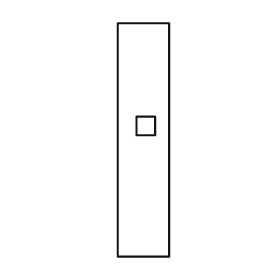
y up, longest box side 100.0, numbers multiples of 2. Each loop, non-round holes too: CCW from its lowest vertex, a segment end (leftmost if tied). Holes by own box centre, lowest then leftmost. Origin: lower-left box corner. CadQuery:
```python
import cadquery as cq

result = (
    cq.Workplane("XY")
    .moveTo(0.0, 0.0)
    .lineTo(22.0, 0.0)
    .lineTo(22.0, 100.0)
    .lineTo(0.0, 100.0)
    .close()
    .moveTo(8.0, 52.0)
    .lineTo(16.0, 52.0)
    .lineTo(16.0, 60.0)
    .lineTo(8.0, 60.0)
    .close()
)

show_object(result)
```